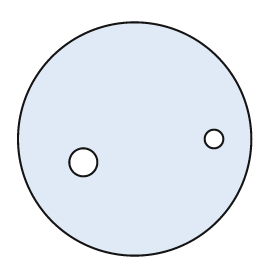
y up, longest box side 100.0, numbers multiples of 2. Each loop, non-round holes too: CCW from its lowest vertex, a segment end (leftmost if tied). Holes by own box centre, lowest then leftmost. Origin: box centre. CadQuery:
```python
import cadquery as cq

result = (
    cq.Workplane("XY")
    .moveTo(0.0, 0.0)
    .circle(50.0)
    .moveTo(-22.0, -10.0)
    .circle(6.0)
    .moveTo(34.0, 0.0)
    .circle(4.0)
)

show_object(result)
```